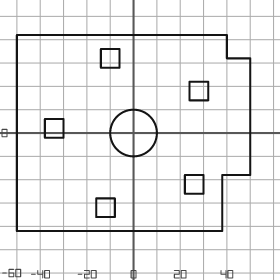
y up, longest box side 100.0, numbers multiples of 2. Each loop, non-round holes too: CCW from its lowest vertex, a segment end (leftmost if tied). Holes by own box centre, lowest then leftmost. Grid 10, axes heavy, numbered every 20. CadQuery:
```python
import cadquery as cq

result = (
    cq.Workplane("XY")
    .moveTo(-50.0, -42.0)
    .lineTo(38.0, -42.0)
    .lineTo(38.0, -18.0)
    .lineTo(50.0, -18.0)
    .lineTo(50.0, 32.0)
    .lineTo(40.0, 32.0)
    .lineTo(40.0, 42.0)
    .lineTo(-50.0, 42.0)
    .close()
    .moveTo(-16.0, -36.0)
    .lineTo(-8.0, -36.0)
    .lineTo(-8.0, -28.0)
    .lineTo(-16.0, -28.0)
    .close()
    .moveTo(22.0, -26.0)
    .lineTo(30.0, -26.0)
    .lineTo(30.0, -18.0)
    .lineTo(22.0, -18.0)
    .close()
    .moveTo(0.0, 0.0)
    .circle(10.0)
    .moveTo(-38.0, -2.0)
    .lineTo(-30.0, -2.0)
    .lineTo(-30.0, 6.0)
    .lineTo(-38.0, 6.0)
    .close()
    .moveTo(24.0, 14.0)
    .lineTo(32.0, 14.0)
    .lineTo(32.0, 22.0)
    .lineTo(24.0, 22.0)
    .close()
    .moveTo(-14.0, 28.0)
    .lineTo(-6.0, 28.0)
    .lineTo(-6.0, 36.0)
    .lineTo(-14.0, 36.0)
    .close()
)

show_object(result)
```